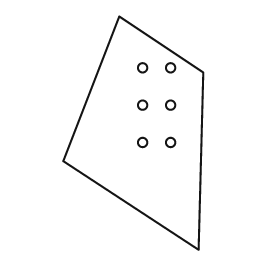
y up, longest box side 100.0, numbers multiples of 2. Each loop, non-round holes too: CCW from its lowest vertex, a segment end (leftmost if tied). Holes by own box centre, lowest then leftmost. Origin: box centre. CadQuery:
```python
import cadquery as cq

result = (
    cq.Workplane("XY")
    .moveTo(28.0, -50.0)
    .lineTo(30.0, 26.0)
    .lineTo(-6.0, 50.0)
    .lineTo(-30.0, -12.0)
    .close()
    .moveTo(4.0, -4.0)
    .circle(2.0)
    .moveTo(16.0, -4.0)
    .circle(2.0)
    .moveTo(4.0, 12.0)
    .circle(2.0)
    .moveTo(16.0, 12.0)
    .circle(2.0)
    .moveTo(4.0, 28.0)
    .circle(2.0)
    .moveTo(16.0, 28.0)
    .circle(2.0)
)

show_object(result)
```